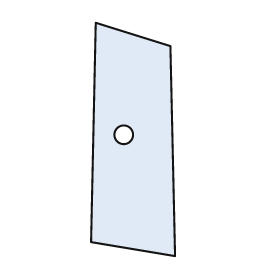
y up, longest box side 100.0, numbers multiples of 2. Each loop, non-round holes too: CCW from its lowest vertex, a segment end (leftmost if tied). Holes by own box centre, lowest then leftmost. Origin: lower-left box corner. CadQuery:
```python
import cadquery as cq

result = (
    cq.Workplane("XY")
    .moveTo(36.0, 0.0)
    .lineTo(34.0, 90.0)
    .lineTo(2.0, 100.0)
    .lineTo(0.0, 6.0)
    .close()
    .moveTo(14.0, 52.0)
    .circle(4.0)
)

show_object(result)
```